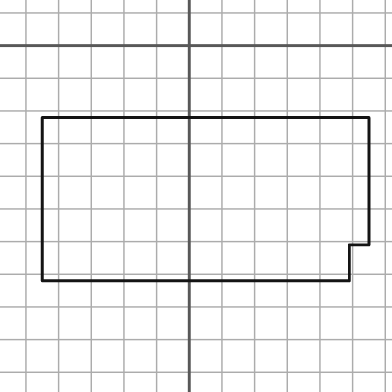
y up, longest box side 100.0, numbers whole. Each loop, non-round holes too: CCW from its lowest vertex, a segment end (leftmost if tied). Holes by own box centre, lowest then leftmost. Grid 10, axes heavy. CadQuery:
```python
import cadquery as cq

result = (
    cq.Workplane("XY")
    .moveTo(-45.0, -72.0)
    .lineTo(49.0, -72.0)
    .lineTo(49.0, -61.0)
    .lineTo(55.0, -61.0)
    .lineTo(55.0, -22.0)
    .lineTo(-45.0, -22.0)
    .close()
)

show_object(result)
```